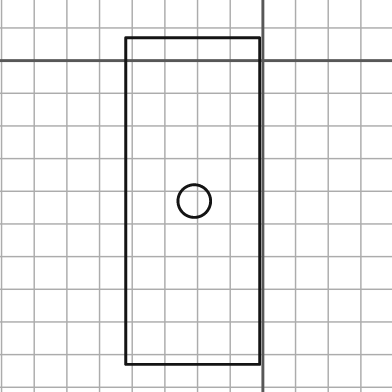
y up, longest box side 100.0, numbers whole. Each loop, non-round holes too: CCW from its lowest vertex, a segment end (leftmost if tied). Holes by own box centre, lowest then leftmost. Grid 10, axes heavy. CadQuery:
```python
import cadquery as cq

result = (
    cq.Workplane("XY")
    .moveTo(-42.0, -93.0)
    .lineTo(-1.0, -93.0)
    .lineTo(-1.0, 7.0)
    .lineTo(-42.0, 7.0)
    .close()
    .moveTo(-21.0, -43.0)
    .circle(5.0)
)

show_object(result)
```